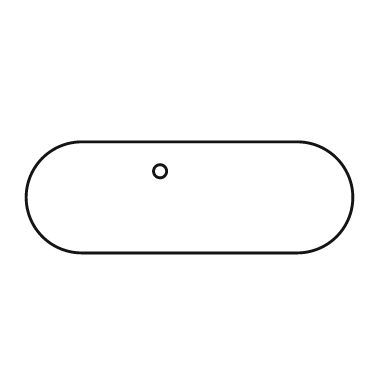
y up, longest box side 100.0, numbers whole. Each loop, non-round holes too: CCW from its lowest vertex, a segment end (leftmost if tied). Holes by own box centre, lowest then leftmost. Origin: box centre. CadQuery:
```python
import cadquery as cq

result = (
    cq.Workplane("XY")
    .moveTo(-33.0, -17.0)
    .lineTo(33.0, -17.0)
    .threePointArc((50.0, 0.0), (33.0, 17.0))
    .lineTo(-33.0, 17.0)
    .threePointArc((-50.0, 0.0), (-33.0, -17.0))
    .close()
    .moveTo(-9.0, 8.0)
    .circle(2.0)
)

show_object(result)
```